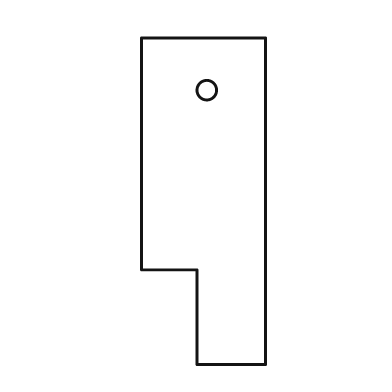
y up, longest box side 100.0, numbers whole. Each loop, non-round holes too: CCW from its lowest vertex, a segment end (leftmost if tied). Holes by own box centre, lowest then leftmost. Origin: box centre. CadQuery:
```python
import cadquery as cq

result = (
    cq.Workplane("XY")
    .moveTo(-2.0, -50.0)
    .lineTo(19.0, -50.0)
    .lineTo(19.0, 50.0)
    .lineTo(-19.0, 50.0)
    .lineTo(-19.0, -21.0)
    .lineTo(-2.0, -21.0)
    .close()
    .moveTo(1.0, 34.0)
    .circle(3.0)
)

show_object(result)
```